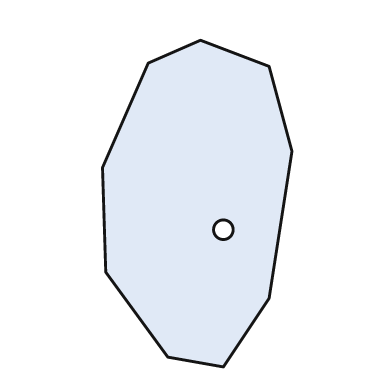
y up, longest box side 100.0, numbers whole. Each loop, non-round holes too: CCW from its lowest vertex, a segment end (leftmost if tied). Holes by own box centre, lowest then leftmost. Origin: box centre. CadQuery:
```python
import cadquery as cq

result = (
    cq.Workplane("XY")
    .moveTo(8.0, -50.0)
    .lineTo(22.0, -29.0)
    .lineTo(29.0, 16.0)
    .lineTo(22.0, 42.0)
    .lineTo(1.0, 50.0)
    .lineTo(-15.0, 43.0)
    .lineTo(-29.0, 11.0)
    .lineTo(-28.0, -21.0)
    .lineTo(-9.0, -47.0)
    .close()
    .moveTo(8.0, -8.0)
    .circle(3.0)
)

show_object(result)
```